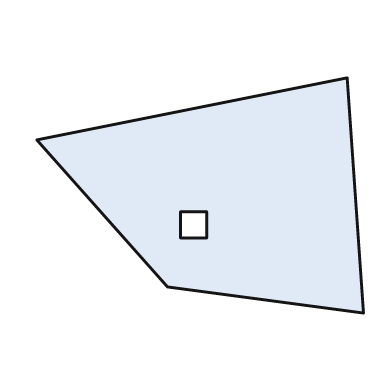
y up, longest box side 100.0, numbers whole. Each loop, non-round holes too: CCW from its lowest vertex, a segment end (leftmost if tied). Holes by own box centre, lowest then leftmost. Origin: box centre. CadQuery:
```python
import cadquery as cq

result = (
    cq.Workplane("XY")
    .moveTo(50.0, -36.0)
    .lineTo(45.0, 36.0)
    .lineTo(-50.0, 17.0)
    .lineTo(-10.0, -28.0)
    .close()
    .moveTo(-6.0, -13.0)
    .lineTo(2.0, -13.0)
    .lineTo(2.0, -5.0)
    .lineTo(-6.0, -5.0)
    .close()
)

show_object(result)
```